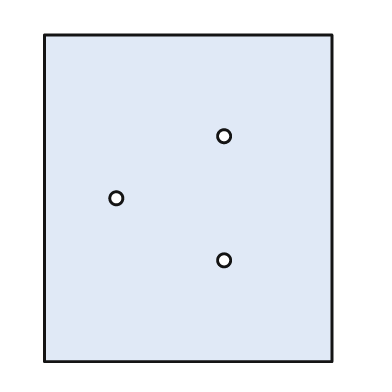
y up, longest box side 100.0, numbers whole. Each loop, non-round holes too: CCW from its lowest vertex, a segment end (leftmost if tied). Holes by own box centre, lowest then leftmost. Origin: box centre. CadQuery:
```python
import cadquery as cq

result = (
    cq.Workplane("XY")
    .moveTo(-44.0, -50.0)
    .lineTo(44.0, -50.0)
    .lineTo(44.0, 50.0)
    .lineTo(-44.0, 50.0)
    .close()
    .moveTo(11.0, -19.0)
    .circle(2.0)
    .moveTo(-22.0, 0.0)
    .circle(2.0)
    .moveTo(11.0, 19.0)
    .circle(2.0)
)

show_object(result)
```